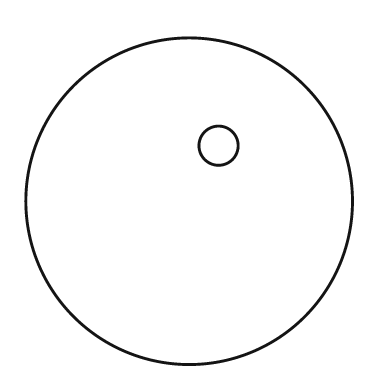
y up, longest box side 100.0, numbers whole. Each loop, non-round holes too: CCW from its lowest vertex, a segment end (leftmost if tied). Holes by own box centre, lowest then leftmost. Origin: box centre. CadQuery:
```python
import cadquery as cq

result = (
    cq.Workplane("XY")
    .moveTo(0.0, 0.0)
    .circle(50.0)
    .moveTo(9.0, 17.0)
    .circle(6.0)
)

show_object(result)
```